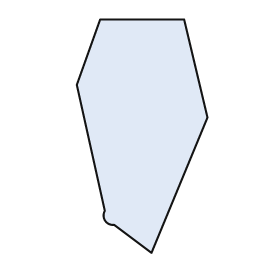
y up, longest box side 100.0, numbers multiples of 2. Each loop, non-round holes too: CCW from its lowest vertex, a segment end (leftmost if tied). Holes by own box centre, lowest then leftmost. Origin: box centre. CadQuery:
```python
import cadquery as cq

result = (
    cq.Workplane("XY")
    .moveTo(4.0, -50.0)
    .lineTo(28.0, 8.0)
    .lineTo(18.0, 50.0)
    .lineTo(-18.0, 50.0)
    .lineTo(-28.0, 22.0)
    .lineTo(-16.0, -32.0)
    .threePointArc((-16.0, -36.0), (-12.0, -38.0))
    .close()
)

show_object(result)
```